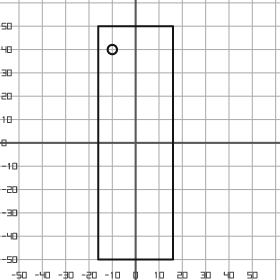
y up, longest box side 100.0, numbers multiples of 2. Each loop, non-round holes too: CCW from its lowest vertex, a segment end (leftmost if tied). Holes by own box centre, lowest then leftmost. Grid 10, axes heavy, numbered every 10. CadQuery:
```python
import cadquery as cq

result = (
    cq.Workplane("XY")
    .moveTo(-16.0, -50.0)
    .lineTo(16.0, -50.0)
    .lineTo(16.0, 50.0)
    .lineTo(-16.0, 50.0)
    .close()
    .moveTo(-10.0, 40.0)
    .circle(2.0)
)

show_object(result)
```